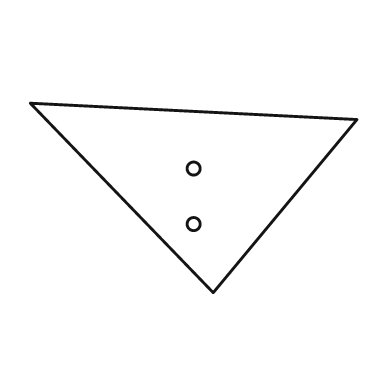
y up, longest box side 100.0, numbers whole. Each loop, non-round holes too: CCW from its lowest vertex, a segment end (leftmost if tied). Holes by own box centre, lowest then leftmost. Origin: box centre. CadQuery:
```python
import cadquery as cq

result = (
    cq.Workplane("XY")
    .moveTo(6.0, -29.0)
    .lineTo(50.0, 24.0)
    .lineTo(-50.0, 29.0)
    .close()
    .moveTo(0.0, -8.0)
    .circle(2.0)
    .moveTo(0.0, 9.0)
    .circle(2.0)
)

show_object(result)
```